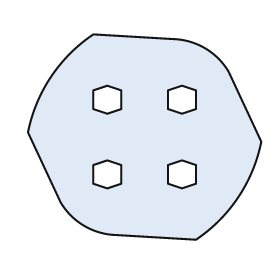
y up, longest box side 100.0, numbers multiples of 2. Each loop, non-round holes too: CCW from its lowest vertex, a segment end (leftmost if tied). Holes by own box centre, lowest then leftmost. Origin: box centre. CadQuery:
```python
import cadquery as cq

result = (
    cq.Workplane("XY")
    .moveTo(22.0, -44.0)
    .threePointArc((40.0, -26.0), (50.0, -2.0))
    .lineTo(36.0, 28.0)
    .threePointArc((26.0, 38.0), (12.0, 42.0))
    .lineTo(-22.0, 44.0)
    .threePointArc((-40.0, 26.0), (-50.0, 2.0))
    .lineTo(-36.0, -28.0)
    .threePointArc((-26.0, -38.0), (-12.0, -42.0))
    .close()
    .moveTo(-16.0, -22.0)
    .lineTo(-10.0, -20.0)
    .lineTo(-10.0, -12.0)
    .lineTo(-16.0, -10.0)
    .lineTo(-22.0, -12.0)
    .lineTo(-22.0, -20.0)
    .close()
    .moveTo(16.0, -22.0)
    .lineTo(22.0, -20.0)
    .lineTo(22.0, -12.0)
    .lineTo(16.0, -10.0)
    .lineTo(10.0, -12.0)
    .lineTo(10.0, -20.0)
    .close()
    .moveTo(-16.0, 10.0)
    .lineTo(-10.0, 12.0)
    .lineTo(-10.0, 20.0)
    .lineTo(-16.0, 22.0)
    .lineTo(-22.0, 20.0)
    .lineTo(-22.0, 12.0)
    .close()
    .moveTo(16.0, 10.0)
    .lineTo(22.0, 12.0)
    .lineTo(22.0, 20.0)
    .lineTo(16.0, 22.0)
    .lineTo(10.0, 20.0)
    .lineTo(10.0, 12.0)
    .close()
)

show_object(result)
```